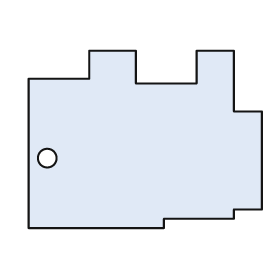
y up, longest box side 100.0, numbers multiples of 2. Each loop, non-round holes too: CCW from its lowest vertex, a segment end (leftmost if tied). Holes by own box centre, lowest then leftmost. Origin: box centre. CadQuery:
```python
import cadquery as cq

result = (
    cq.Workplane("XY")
    .moveTo(-50.0, -38.0)
    .lineTo(8.0, -38.0)
    .lineTo(8.0, -34.0)
    .lineTo(38.0, -34.0)
    .lineTo(38.0, -30.0)
    .lineTo(50.0, -30.0)
    .lineTo(50.0, 12.0)
    .lineTo(38.0, 12.0)
    .lineTo(38.0, 38.0)
    .lineTo(22.0, 38.0)
    .lineTo(22.0, 24.0)
    .lineTo(-4.0, 24.0)
    .lineTo(-4.0, 38.0)
    .lineTo(-24.0, 38.0)
    .lineTo(-24.0, 26.0)
    .lineTo(-50.0, 26.0)
    .close()
    .moveTo(-42.0, -8.0)
    .circle(4.0)
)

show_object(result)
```